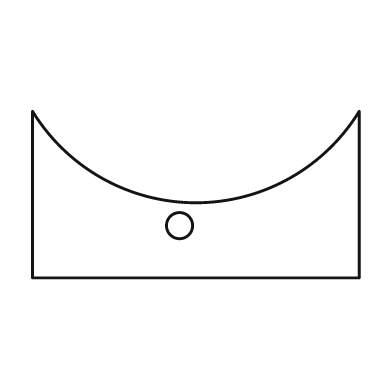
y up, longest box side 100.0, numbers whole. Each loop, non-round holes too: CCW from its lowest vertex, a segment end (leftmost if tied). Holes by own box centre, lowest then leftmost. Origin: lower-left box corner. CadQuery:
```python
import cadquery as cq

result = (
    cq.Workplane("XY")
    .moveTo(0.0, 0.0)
    .lineTo(100.0, 0.0)
    .lineTo(100.0, 51.0)
    .threePointArc((50.0, 23.0), (0.0, 51.0))
    .close()
    .moveTo(45.0, 16.0)
    .circle(4.0)
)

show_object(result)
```